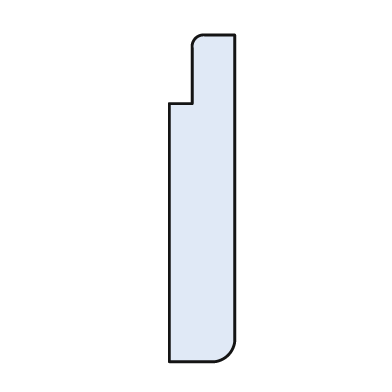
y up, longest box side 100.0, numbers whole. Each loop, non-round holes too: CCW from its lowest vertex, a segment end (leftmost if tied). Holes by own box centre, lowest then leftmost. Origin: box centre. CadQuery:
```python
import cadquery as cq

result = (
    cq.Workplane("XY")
    .moveTo(-10.0, -50.0)
    .lineTo(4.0, -50.0)
    .threePointArc((8.0, -48.0), (10.0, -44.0))
    .lineTo(10.0, 50.0)
    .lineTo(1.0, 50.0)
    .threePointArc((-2.0, 49.0), (-3.0, 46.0))
    .lineTo(-3.0, 29.0)
    .lineTo(-10.0, 29.0)
    .close()
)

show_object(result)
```